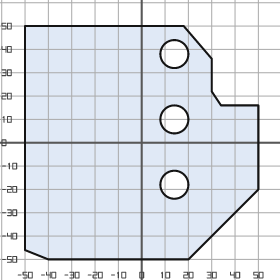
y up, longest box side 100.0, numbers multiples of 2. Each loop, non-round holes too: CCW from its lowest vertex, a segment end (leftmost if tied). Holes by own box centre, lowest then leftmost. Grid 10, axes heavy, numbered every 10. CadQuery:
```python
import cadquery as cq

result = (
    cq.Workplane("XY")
    .moveTo(-40.0, -50.0)
    .lineTo(20.0, -50.0)
    .lineTo(50.0, -20.0)
    .lineTo(50.0, 16.0)
    .lineTo(34.0, 16.0)
    .lineTo(30.0, 22.0)
    .lineTo(30.0, 36.0)
    .lineTo(18.0, 50.0)
    .lineTo(-50.0, 50.0)
    .lineTo(-50.0, -46.0)
    .close()
    .moveTo(14.0, -18.0)
    .circle(6.0)
    .moveTo(14.0, 10.0)
    .circle(6.0)
    .moveTo(14.0, 38.0)
    .circle(6.0)
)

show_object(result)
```